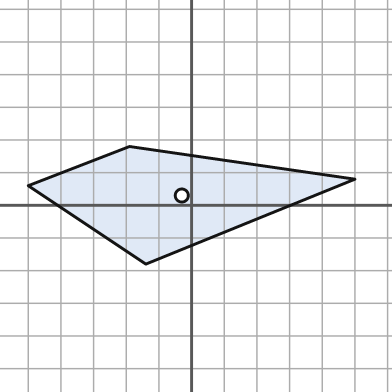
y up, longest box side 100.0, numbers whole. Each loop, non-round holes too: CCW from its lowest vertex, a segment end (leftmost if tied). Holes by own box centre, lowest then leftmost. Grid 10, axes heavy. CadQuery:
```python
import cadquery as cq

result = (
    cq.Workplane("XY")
    .moveTo(-14.0, -18.0)
    .lineTo(50.0, 8.0)
    .lineTo(-19.0, 18.0)
    .lineTo(-50.0, 6.0)
    .close()
    .moveTo(-3.0, 3.0)
    .circle(2.0)
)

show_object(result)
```